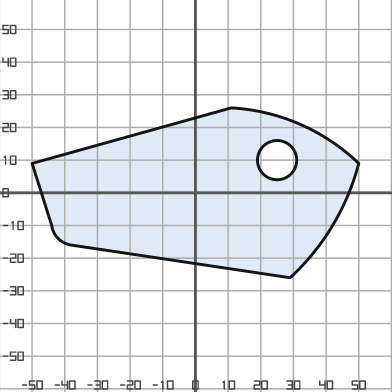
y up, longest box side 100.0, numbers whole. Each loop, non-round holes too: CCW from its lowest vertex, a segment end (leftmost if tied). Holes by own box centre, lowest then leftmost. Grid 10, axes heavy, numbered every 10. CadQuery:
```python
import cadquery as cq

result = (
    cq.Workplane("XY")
    .moveTo(29.0, -26.0)
    .threePointArc((42.0, -10.0), (50.0, 9.0))
    .threePointArc((32.0, 21.0), (11.0, 26.0))
    .lineTo(-50.0, 9.0)
    .lineTo(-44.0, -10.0)
    .threePointArc((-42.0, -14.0), (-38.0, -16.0))
    .close()
    .moveTo(25.0, 10.0)
    .circle(6.0)
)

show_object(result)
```